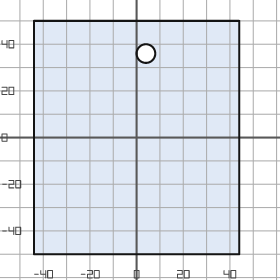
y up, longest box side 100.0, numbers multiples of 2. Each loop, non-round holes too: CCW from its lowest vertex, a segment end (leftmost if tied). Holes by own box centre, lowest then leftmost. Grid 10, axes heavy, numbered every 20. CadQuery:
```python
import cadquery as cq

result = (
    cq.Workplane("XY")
    .moveTo(-44.0, -50.0)
    .lineTo(44.0, -50.0)
    .lineTo(44.0, 50.0)
    .lineTo(-44.0, 50.0)
    .close()
    .moveTo(4.0, 36.0)
    .circle(4.0)
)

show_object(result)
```